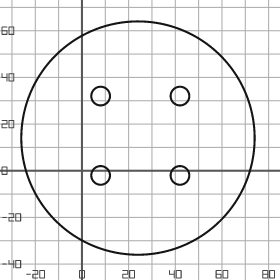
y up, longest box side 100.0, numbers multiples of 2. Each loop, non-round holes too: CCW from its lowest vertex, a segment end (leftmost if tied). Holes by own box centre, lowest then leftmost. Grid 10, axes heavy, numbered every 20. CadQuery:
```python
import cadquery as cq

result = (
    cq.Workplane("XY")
    .moveTo(24.0, 14.0)
    .circle(50.0)
    .moveTo(8.0, -2.0)
    .circle(4.0)
    .moveTo(42.0, -2.0)
    .circle(4.0)
    .moveTo(8.0, 32.0)
    .circle(4.0)
    .moveTo(42.0, 32.0)
    .circle(4.0)
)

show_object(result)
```